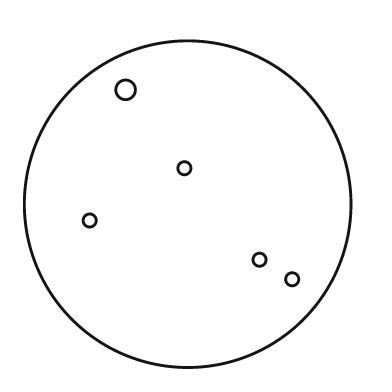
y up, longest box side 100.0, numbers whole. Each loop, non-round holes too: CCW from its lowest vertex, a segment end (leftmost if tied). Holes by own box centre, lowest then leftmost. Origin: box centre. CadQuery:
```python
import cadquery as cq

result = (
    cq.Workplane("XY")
    .moveTo(0.0, 0.0)
    .circle(50.0)
    .moveTo(32.0, -23.0)
    .circle(2.0)
    .moveTo(22.0, -17.0)
    .circle(2.0)
    .moveTo(-30.0, -5.0)
    .circle(2.0)
    .moveTo(-1.0, 11.0)
    .circle(2.0)
    .moveTo(-19.0, 35.0)
    .circle(3.0)
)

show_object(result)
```